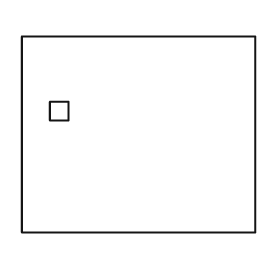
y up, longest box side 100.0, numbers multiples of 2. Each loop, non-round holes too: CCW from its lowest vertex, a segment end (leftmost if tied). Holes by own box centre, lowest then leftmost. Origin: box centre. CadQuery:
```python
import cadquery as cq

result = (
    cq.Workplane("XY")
    .moveTo(-50.0, -42.0)
    .lineTo(50.0, -42.0)
    .lineTo(50.0, 42.0)
    .lineTo(-50.0, 42.0)
    .close()
    .moveTo(-38.0, 6.0)
    .lineTo(-30.0, 6.0)
    .lineTo(-30.0, 14.0)
    .lineTo(-38.0, 14.0)
    .close()
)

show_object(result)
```